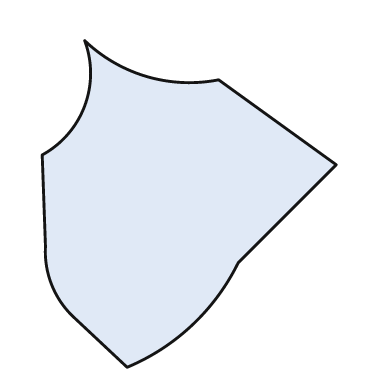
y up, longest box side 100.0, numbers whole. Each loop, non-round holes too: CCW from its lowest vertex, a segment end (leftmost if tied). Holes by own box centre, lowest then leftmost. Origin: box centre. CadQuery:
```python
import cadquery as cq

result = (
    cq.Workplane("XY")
    .moveTo(-19.0, -50.0)
    .threePointArc((1.0, -37.0), (15.0, -18.0))
    .lineTo(45.0, 12.0)
    .lineTo(9.0, 38.0)
    .threePointArc((-13.0, 39.0), (-32.0, 50.0))
    .threePointArc((-32.0, 30.0), (-45.0, 15.0))
    .lineTo(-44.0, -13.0)
    .threePointArc((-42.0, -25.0), (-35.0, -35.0))
    .close()
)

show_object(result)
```